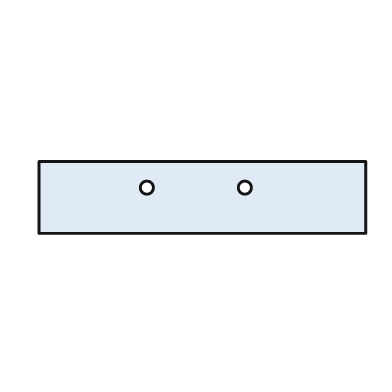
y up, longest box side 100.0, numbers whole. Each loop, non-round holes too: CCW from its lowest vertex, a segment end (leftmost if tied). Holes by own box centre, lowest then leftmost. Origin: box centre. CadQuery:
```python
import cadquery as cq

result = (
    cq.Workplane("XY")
    .moveTo(-50.0, -11.0)
    .lineTo(50.0, -11.0)
    .lineTo(50.0, 11.0)
    .lineTo(-50.0, 11.0)
    .close()
    .moveTo(-17.0, 3.0)
    .circle(2.0)
    .moveTo(13.0, 3.0)
    .circle(2.0)
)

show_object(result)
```